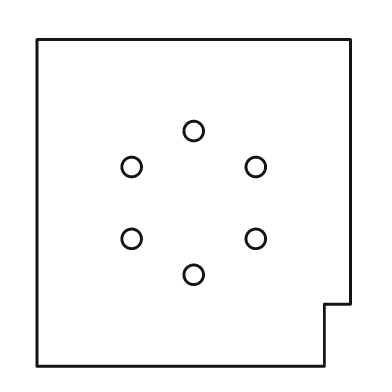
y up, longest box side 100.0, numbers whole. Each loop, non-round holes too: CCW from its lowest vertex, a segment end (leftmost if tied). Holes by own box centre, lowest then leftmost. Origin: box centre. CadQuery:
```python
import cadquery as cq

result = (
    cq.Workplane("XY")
    .moveTo(-48.0, -50.0)
    .lineTo(40.0, -50.0)
    .lineTo(40.0, -31.0)
    .lineTo(48.0, -31.0)
    .lineTo(48.0, 50.0)
    .lineTo(-48.0, 50.0)
    .close()
    .moveTo(0.0, -22.0)
    .circle(3.0)
    .moveTo(-19.0, -11.0)
    .circle(3.0)
    .moveTo(19.0, -11.0)
    .circle(3.0)
    .moveTo(-19.0, 11.0)
    .circle(3.0)
    .moveTo(19.0, 11.0)
    .circle(3.0)
    .moveTo(0.0, 22.0)
    .circle(3.0)
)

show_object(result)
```